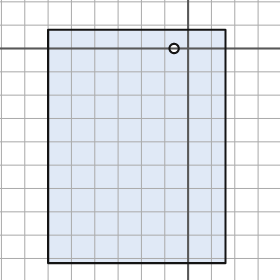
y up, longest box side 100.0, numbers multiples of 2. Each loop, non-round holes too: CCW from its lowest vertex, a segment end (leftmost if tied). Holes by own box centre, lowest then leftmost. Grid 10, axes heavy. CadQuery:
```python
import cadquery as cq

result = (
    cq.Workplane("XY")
    .moveTo(-60.0, -92.0)
    .lineTo(16.0, -92.0)
    .lineTo(16.0, 8.0)
    .lineTo(-60.0, 8.0)
    .close()
    .moveTo(-6.0, 0.0)
    .circle(2.0)
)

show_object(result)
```